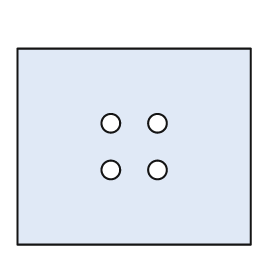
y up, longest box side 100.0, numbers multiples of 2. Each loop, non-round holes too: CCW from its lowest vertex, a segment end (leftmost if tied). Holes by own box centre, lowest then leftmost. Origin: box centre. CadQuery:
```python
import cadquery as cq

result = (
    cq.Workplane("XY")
    .moveTo(-50.0, -42.0)
    .lineTo(50.0, -42.0)
    .lineTo(50.0, 42.0)
    .lineTo(-50.0, 42.0)
    .close()
    .moveTo(-10.0, -10.0)
    .circle(4.0)
    .moveTo(10.0, -10.0)
    .circle(4.0)
    .moveTo(-10.0, 10.0)
    .circle(4.0)
    .moveTo(10.0, 10.0)
    .circle(4.0)
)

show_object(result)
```